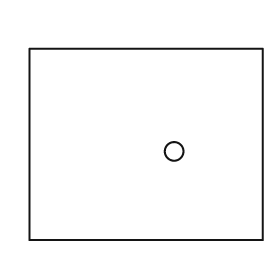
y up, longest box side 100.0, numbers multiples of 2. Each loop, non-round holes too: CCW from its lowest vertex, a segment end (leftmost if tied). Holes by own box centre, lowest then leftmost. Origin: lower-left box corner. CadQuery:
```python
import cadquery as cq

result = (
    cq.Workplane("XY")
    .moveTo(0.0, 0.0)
    .lineTo(100.0, 0.0)
    .lineTo(100.0, 82.0)
    .lineTo(0.0, 82.0)
    .close()
    .moveTo(62.0, 38.0)
    .circle(4.0)
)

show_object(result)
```